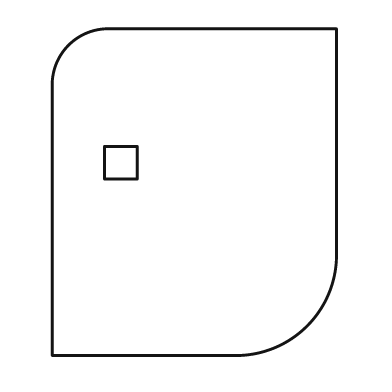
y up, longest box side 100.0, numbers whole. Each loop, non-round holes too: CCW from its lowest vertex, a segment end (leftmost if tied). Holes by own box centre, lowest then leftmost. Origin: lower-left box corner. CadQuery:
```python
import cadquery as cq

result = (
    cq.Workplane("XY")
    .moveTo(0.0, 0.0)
    .lineTo(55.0, 0.0)
    .threePointArc((78.0, 9.0), (87.0, 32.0))
    .lineTo(87.0, 100.0)
    .lineTo(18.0, 100.0)
    .threePointArc((5.0, 95.0), (0.0, 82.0))
    .close()
    .moveTo(16.0, 54.0)
    .lineTo(26.0, 54.0)
    .lineTo(26.0, 64.0)
    .lineTo(16.0, 64.0)
    .close()
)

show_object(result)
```